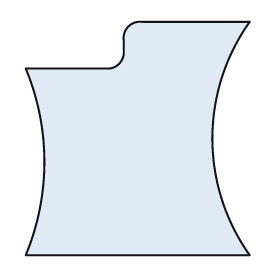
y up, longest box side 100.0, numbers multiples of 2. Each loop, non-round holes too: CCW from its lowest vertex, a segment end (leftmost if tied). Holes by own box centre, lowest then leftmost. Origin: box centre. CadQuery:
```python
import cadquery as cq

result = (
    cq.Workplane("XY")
    .moveTo(-48.0, -50.0)
    .lineTo(48.0, -50.0)
    .threePointArc((32.0, 0.0), (48.0, 50.0))
    .lineTo(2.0, 50.0)
    .threePointArc((-4.0, 48.0), (-6.0, 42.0))
    .lineTo(-6.0, 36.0)
    .threePointArc((-8.0, 32.0), (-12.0, 30.0))
    .lineTo(-48.0, 30.0)
    .threePointArc((-40.0, -10.0), (-48.0, -50.0))
    .close()
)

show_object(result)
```